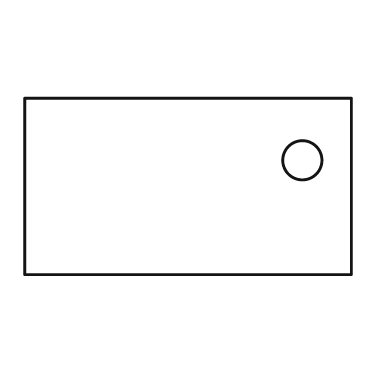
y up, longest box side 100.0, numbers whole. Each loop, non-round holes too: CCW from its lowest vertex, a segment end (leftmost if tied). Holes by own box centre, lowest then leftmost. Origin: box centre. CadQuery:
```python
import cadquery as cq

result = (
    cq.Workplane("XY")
    .moveTo(-50.0, -27.0)
    .lineTo(50.0, -27.0)
    .lineTo(50.0, 27.0)
    .lineTo(-50.0, 27.0)
    .close()
    .moveTo(35.0, 8.0)
    .circle(6.0)
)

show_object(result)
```